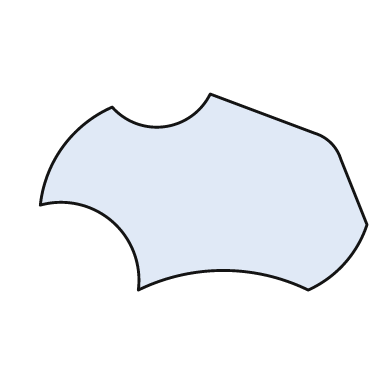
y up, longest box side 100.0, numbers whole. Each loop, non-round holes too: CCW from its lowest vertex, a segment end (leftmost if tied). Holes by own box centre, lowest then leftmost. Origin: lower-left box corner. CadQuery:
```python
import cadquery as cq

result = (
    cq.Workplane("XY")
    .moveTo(30.0, 0.0)
    .threePointArc((56.0, 6.0), (82.0, 0.0))
    .threePointArc((93.0, 8.0), (100.0, 20.0))
    .lineTo(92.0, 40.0)
    .threePointArc((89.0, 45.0), (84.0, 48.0))
    .lineTo(52.0, 60.0)
    .threePointArc((38.0, 50.0), (22.0, 56.0))
    .threePointArc((7.0, 44.0), (0.0, 26.0))
    .threePointArc((22.0, 21.0), (30.0, 0.0))
    .close()
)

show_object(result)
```